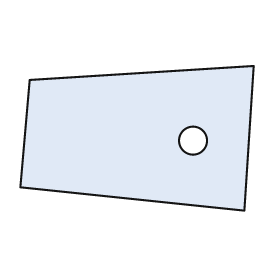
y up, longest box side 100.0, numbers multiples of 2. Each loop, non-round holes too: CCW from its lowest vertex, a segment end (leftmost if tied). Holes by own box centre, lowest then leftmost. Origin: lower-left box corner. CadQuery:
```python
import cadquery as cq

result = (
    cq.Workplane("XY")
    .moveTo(96.0, 0.0)
    .lineTo(100.0, 62.0)
    .lineTo(4.0, 56.0)
    .lineTo(0.0, 10.0)
    .close()
    .moveTo(74.0, 30.0)
    .circle(6.0)
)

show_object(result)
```